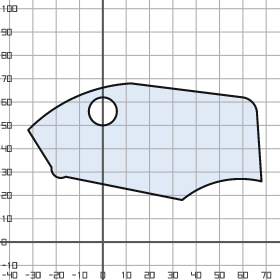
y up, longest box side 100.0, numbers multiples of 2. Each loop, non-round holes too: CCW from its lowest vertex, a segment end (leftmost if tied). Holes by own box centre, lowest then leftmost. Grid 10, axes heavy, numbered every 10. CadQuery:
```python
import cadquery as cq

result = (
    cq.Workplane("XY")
    .moveTo(34.0, 18.0)
    .threePointArc((50.0, 26.0), (68.0, 26.0))
    .lineTo(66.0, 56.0)
    .threePointArc((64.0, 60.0), (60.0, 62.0))
    .lineTo(12.0, 68.0)
    .threePointArc((-12.0, 62.0), (-32.0, 48.0))
    .lineTo(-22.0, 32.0)
    .threePointArc((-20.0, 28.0), (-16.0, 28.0))
    .close()
    .moveTo(0.0, 56.0)
    .circle(6.0)
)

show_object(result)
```